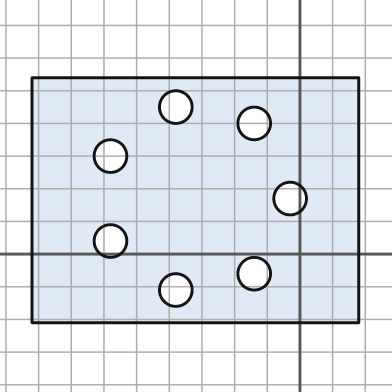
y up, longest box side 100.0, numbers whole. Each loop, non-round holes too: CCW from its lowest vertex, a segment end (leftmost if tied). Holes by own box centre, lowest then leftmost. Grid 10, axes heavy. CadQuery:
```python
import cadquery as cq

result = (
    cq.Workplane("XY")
    .moveTo(-82.0, -21.0)
    .lineTo(18.0, -21.0)
    .lineTo(18.0, 54.0)
    .lineTo(-82.0, 54.0)
    .close()
    .moveTo(-38.0, -11.0)
    .circle(5.0)
    .moveTo(-14.0, -6.0)
    .circle(5.0)
    .moveTo(-58.0, 4.0)
    .circle(5.0)
    .moveTo(-3.0, 17.0)
    .circle(5.0)
    .moveTo(-58.0, 30.0)
    .circle(5.0)
    .moveTo(-14.0, 40.0)
    .circle(5.0)
    .moveTo(-38.0, 45.0)
    .circle(5.0)
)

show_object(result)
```